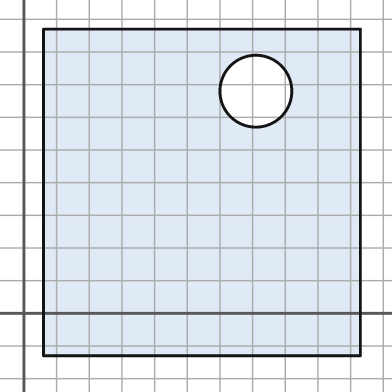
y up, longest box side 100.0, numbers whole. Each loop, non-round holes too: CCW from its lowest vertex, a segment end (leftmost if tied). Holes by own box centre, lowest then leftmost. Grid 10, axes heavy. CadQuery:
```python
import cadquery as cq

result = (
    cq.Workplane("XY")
    .moveTo(6.0, -13.0)
    .lineTo(103.0, -13.0)
    .lineTo(103.0, 87.0)
    .lineTo(6.0, 87.0)
    .close()
    .moveTo(71.0, 68.0)
    .circle(11.0)
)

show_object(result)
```